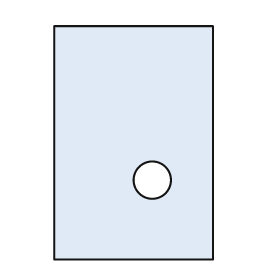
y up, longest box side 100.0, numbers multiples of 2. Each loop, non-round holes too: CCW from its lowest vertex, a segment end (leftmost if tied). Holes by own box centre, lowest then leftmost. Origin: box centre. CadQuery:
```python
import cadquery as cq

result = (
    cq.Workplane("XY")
    .moveTo(-34.0, -50.0)
    .lineTo(34.0, -50.0)
    .lineTo(34.0, 50.0)
    .lineTo(-34.0, 50.0)
    .close()
    .moveTo(8.0, -16.0)
    .circle(8.0)
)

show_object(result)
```